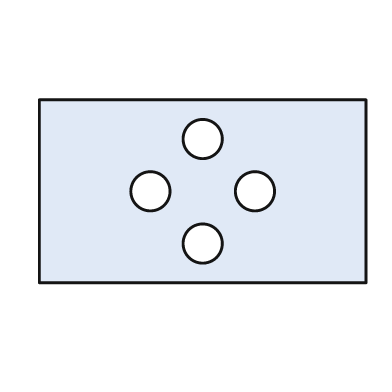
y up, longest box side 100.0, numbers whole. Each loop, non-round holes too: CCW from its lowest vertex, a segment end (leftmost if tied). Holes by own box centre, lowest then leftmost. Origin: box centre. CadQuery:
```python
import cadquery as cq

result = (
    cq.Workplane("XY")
    .moveTo(-50.0, -28.0)
    .lineTo(50.0, -28.0)
    .lineTo(50.0, 28.0)
    .lineTo(-50.0, 28.0)
    .close()
    .moveTo(0.0, -16.0)
    .circle(6.0)
    .moveTo(-16.0, 0.0)
    .circle(6.0)
    .moveTo(16.0, 0.0)
    .circle(6.0)
    .moveTo(0.0, 16.0)
    .circle(6.0)
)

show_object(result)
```